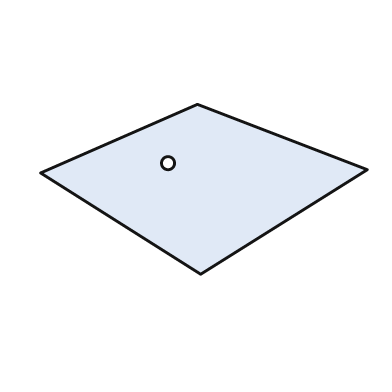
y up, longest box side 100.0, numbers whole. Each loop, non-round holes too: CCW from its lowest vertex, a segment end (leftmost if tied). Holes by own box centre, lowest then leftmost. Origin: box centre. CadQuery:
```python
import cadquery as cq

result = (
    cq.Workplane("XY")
    .moveTo(-1.0, -26.0)
    .lineTo(50.0, 6.0)
    .lineTo(-2.0, 26.0)
    .lineTo(-50.0, 5.0)
    .close()
    .moveTo(-11.0, 8.0)
    .circle(2.0)
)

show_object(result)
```